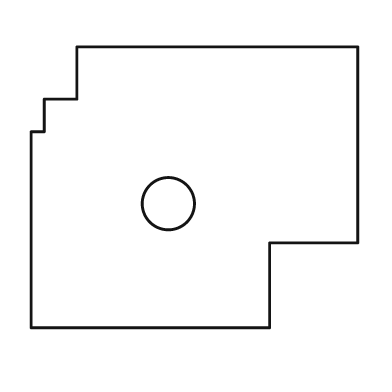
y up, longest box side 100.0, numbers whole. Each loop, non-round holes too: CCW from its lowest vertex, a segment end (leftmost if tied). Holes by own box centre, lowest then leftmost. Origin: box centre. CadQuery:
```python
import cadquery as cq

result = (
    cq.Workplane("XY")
    .moveTo(-50.0, -43.0)
    .lineTo(23.0, -43.0)
    .lineTo(23.0, -17.0)
    .lineTo(50.0, -17.0)
    .lineTo(50.0, 43.0)
    .lineTo(-36.0, 43.0)
    .lineTo(-36.0, 27.0)
    .lineTo(-46.0, 27.0)
    .lineTo(-46.0, 17.0)
    .lineTo(-50.0, 17.0)
    .close()
    .moveTo(-8.0, -5.0)
    .circle(8.0)
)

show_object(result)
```